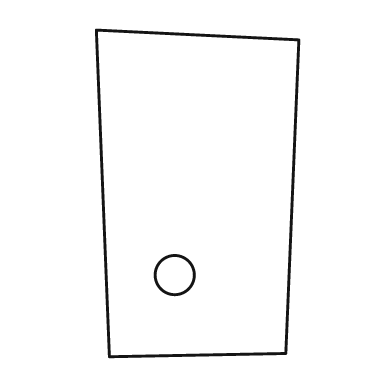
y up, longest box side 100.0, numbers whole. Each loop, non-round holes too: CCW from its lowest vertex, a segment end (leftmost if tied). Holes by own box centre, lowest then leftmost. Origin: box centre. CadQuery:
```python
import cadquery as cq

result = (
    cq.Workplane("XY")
    .moveTo(-27.0, -50.0)
    .lineTo(27.0, -49.0)
    .lineTo(31.0, 47.0)
    .lineTo(-31.0, 50.0)
    .close()
    .moveTo(-7.0, -25.0)
    .circle(6.0)
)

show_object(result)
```